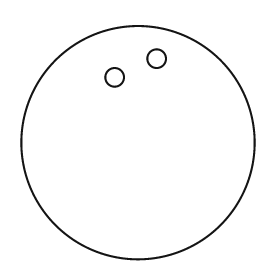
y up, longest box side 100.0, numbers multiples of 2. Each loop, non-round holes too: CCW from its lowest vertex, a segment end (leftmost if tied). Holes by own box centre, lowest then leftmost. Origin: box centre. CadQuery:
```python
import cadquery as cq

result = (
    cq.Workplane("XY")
    .moveTo(0.0, 0.0)
    .circle(50.0)
    .moveTo(-10.0, 28.0)
    .circle(4.0)
    .moveTo(8.0, 36.0)
    .circle(4.0)
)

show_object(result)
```